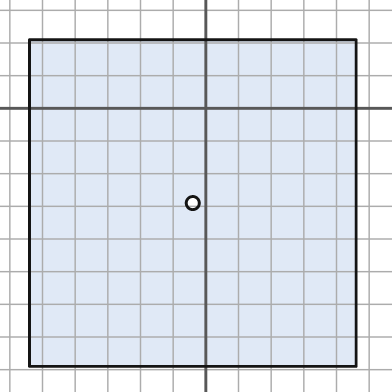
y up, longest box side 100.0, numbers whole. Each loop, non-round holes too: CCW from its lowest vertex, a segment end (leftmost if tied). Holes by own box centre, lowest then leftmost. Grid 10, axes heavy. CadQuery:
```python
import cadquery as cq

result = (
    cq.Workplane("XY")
    .moveTo(-54.0, -79.0)
    .lineTo(46.0, -79.0)
    .lineTo(46.0, 21.0)
    .lineTo(-54.0, 21.0)
    .close()
    .moveTo(-4.0, -29.0)
    .circle(2.0)
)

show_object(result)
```